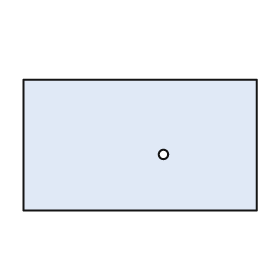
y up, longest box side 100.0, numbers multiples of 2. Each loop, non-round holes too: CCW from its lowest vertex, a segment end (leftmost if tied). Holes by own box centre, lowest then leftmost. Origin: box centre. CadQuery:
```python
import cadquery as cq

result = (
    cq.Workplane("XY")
    .moveTo(-50.0, -28.0)
    .lineTo(50.0, -28.0)
    .lineTo(50.0, 28.0)
    .lineTo(-50.0, 28.0)
    .close()
    .moveTo(10.0, -4.0)
    .circle(2.0)
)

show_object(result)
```